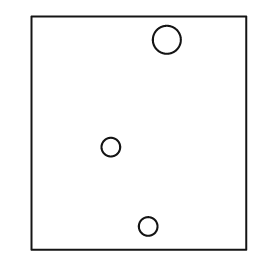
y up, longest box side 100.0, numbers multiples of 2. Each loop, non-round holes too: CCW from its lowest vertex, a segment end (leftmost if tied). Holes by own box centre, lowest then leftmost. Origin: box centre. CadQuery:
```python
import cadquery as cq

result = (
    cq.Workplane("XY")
    .moveTo(-46.0, -50.0)
    .lineTo(46.0, -50.0)
    .lineTo(46.0, 50.0)
    .lineTo(-46.0, 50.0)
    .close()
    .moveTo(4.0, -40.0)
    .circle(4.0)
    .moveTo(-12.0, -6.0)
    .circle(4.0)
    .moveTo(12.0, 40.0)
    .circle(6.0)
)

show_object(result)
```